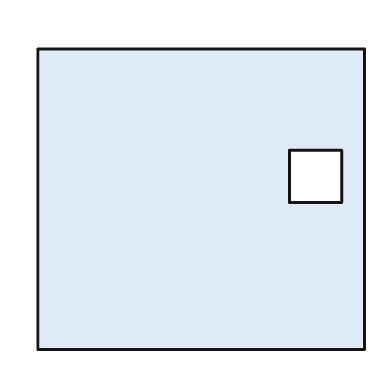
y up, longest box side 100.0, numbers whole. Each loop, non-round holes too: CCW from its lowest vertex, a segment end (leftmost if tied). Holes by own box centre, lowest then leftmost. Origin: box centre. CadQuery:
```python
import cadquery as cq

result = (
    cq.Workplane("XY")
    .moveTo(-50.0, -46.0)
    .lineTo(50.0, -46.0)
    .lineTo(50.0, 46.0)
    .lineTo(-50.0, 46.0)
    .close()
    .moveTo(27.0, -1.0)
    .lineTo(43.0, -1.0)
    .lineTo(43.0, 15.0)
    .lineTo(27.0, 15.0)
    .close()
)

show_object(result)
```